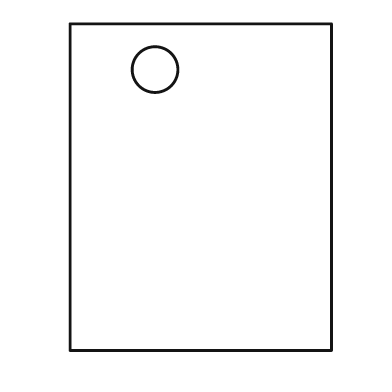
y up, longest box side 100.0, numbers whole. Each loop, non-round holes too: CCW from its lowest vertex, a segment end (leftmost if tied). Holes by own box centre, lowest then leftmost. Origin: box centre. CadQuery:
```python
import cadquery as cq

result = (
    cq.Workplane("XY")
    .moveTo(-40.0, -50.0)
    .lineTo(40.0, -50.0)
    .lineTo(40.0, 50.0)
    .lineTo(-40.0, 50.0)
    .close()
    .moveTo(-14.0, 36.0)
    .circle(7.0)
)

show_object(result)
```